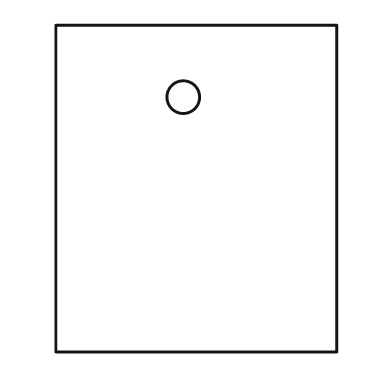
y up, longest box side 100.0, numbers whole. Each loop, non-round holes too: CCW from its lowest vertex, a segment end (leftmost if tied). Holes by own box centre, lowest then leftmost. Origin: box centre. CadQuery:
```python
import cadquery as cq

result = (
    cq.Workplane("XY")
    .moveTo(-43.0, -50.0)
    .lineTo(43.0, -50.0)
    .lineTo(43.0, 50.0)
    .lineTo(-43.0, 50.0)
    .close()
    .moveTo(-4.0, 28.0)
    .circle(5.0)
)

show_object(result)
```